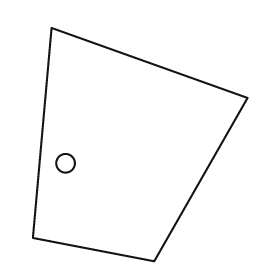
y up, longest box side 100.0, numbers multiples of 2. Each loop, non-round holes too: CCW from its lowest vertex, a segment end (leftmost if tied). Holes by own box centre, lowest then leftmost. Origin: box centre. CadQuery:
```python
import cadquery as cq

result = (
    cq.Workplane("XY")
    .moveTo(6.0, -50.0)
    .lineTo(46.0, 20.0)
    .lineTo(-38.0, 50.0)
    .lineTo(-46.0, -40.0)
    .close()
    .moveTo(-32.0, -8.0)
    .circle(4.0)
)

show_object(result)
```